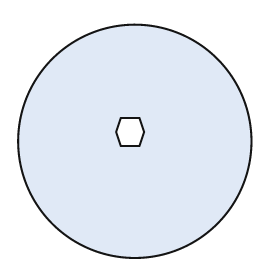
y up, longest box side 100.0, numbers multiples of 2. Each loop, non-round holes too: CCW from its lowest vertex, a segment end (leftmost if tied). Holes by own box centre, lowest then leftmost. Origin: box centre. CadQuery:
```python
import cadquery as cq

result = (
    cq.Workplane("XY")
    .moveTo(0.0, 0.0)
    .circle(50.0)
    .moveTo(-6.0, -2.0)
    .lineTo(2.0, -2.0)
    .lineTo(4.0, 4.0)
    .lineTo(2.0, 10.0)
    .lineTo(-6.0, 10.0)
    .lineTo(-8.0, 4.0)
    .close()
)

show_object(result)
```